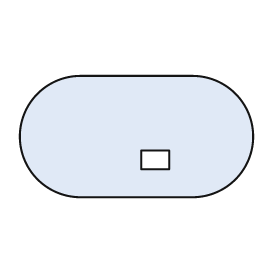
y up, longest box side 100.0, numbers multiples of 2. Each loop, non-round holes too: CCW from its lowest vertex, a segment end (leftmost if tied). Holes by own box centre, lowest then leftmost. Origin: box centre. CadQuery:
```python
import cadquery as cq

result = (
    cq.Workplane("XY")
    .moveTo(-24.0, -26.0)
    .lineTo(24.0, -26.0)
    .threePointArc((50.0, 0.0), (24.0, 26.0))
    .lineTo(-24.0, 26.0)
    .threePointArc((-50.0, 0.0), (-24.0, -26.0))
    .close()
    .moveTo(2.0, -14.0)
    .lineTo(14.0, -14.0)
    .lineTo(14.0, -6.0)
    .lineTo(2.0, -6.0)
    .close()
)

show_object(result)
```